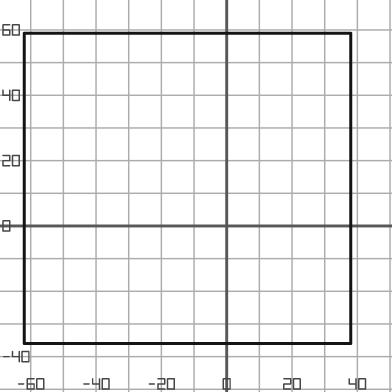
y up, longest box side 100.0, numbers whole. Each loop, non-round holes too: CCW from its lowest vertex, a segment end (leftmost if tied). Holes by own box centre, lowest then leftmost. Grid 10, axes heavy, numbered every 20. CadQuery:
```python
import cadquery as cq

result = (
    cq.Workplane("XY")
    .moveTo(-62.0, -36.0)
    .lineTo(38.0, -36.0)
    .lineTo(38.0, 59.0)
    .lineTo(-62.0, 59.0)
    .close()
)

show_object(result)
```